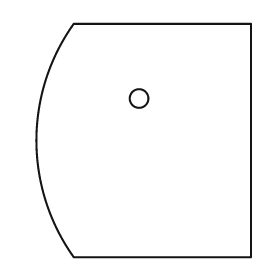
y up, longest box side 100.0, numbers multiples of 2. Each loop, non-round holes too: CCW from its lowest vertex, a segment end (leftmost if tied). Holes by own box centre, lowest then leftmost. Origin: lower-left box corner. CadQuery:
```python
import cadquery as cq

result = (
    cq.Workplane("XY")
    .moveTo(16.0, 0.0)
    .lineTo(92.0, 0.0)
    .lineTo(92.0, 100.0)
    .lineTo(16.0, 100.0)
    .threePointArc((0.0, 50.0), (16.0, 0.0))
    .close()
    .moveTo(44.0, 68.0)
    .circle(4.0)
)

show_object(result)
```